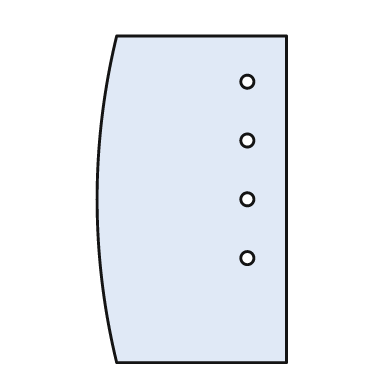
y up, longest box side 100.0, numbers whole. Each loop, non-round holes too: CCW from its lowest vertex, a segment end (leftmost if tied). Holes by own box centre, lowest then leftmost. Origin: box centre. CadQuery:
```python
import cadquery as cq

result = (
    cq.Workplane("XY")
    .moveTo(-23.0, -50.0)
    .lineTo(29.0, -50.0)
    .lineTo(29.0, 50.0)
    .lineTo(-23.0, 50.0)
    .threePointArc((-29.0, 0.0), (-23.0, -50.0))
    .close()
    .moveTo(17.0, -18.0)
    .circle(2.0)
    .moveTo(17.0, 0.0)
    .circle(2.0)
    .moveTo(17.0, 18.0)
    .circle(2.0)
    .moveTo(17.0, 36.0)
    .circle(2.0)
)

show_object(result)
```